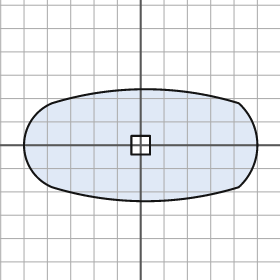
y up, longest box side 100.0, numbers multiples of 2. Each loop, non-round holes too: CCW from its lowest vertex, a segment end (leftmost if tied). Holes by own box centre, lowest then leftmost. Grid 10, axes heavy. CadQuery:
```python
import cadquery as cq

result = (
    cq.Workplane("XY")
    .moveTo(-38.0, -18.0)
    .threePointArc((2.0, -24.0), (42.0, -18.0))
    .threePointArc((50.0, 0.0), (42.0, 18.0))
    .threePointArc((2.0, 24.0), (-38.0, 18.0))
    .threePointArc((-50.0, 0.0), (-38.0, -18.0))
    .close()
    .moveTo(-4.0, -4.0)
    .lineTo(4.0, -4.0)
    .lineTo(4.0, 4.0)
    .lineTo(-4.0, 4.0)
    .close()
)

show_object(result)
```